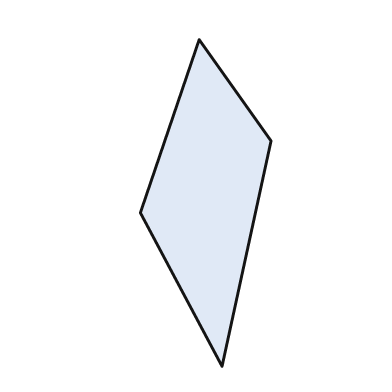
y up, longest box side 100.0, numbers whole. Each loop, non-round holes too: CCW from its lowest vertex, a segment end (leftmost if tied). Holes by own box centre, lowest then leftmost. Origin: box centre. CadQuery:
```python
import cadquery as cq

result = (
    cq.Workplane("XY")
    .moveTo(5.0, -50.0)
    .lineTo(20.0, 19.0)
    .lineTo(-2.0, 50.0)
    .lineTo(-20.0, -3.0)
    .close()
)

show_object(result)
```